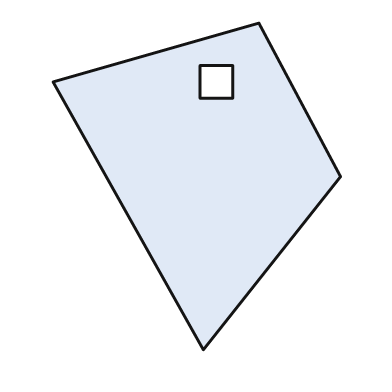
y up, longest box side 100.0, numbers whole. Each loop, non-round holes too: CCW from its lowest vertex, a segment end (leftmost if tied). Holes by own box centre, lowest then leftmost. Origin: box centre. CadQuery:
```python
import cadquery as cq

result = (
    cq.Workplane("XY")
    .moveTo(2.0, -50.0)
    .lineTo(44.0, 3.0)
    .lineTo(19.0, 50.0)
    .lineTo(-44.0, 32.0)
    .close()
    .moveTo(1.0, 27.0)
    .lineTo(11.0, 27.0)
    .lineTo(11.0, 37.0)
    .lineTo(1.0, 37.0)
    .close()
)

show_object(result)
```